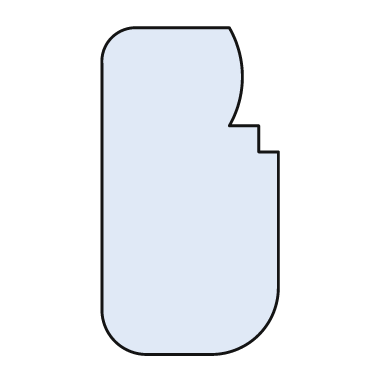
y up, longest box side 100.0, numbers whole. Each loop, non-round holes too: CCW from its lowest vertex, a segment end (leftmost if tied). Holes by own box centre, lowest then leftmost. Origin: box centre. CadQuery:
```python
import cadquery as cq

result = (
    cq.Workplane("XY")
    .moveTo(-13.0, -50.0)
    .lineTo(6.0, -50.0)
    .threePointArc((21.0, -44.0), (27.0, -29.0))
    .lineTo(27.0, 12.0)
    .lineTo(21.0, 12.0)
    .lineTo(21.0, 20.0)
    .lineTo(12.0, 20.0)
    .threePointArc((16.0, 35.0), (12.0, 50.0))
    .lineTo(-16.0, 50.0)
    .threePointArc((-24.0, 47.0), (-27.0, 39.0))
    .lineTo(-27.0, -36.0)
    .threePointArc((-23.0, -46.0), (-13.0, -50.0))
    .close()
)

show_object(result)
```